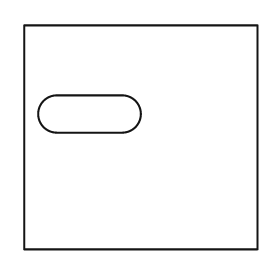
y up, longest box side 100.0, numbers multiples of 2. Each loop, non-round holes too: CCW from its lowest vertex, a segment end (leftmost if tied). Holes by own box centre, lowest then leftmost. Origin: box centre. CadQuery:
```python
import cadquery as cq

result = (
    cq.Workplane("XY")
    .moveTo(-50.0, -48.0)
    .lineTo(50.0, -48.0)
    .lineTo(50.0, 48.0)
    .lineTo(-50.0, 48.0)
    .close()
    .moveTo(-36.0, 2.0)
    .lineTo(-8.0, 2.0)
    .threePointArc((0.0, 10.0), (-8.0, 18.0))
    .lineTo(-36.0, 18.0)
    .threePointArc((-44.0, 10.0), (-36.0, 2.0))
    .close()
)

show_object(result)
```